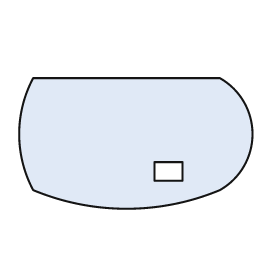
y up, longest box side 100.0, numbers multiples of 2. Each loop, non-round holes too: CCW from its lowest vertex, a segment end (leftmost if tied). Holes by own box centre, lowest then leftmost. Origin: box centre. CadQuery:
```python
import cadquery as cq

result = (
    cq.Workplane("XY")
    .moveTo(-44.0, -20.0)
    .threePointArc((-4.0, -28.0), (36.0, -20.0))
    .threePointArc((50.0, 4.0), (36.0, 28.0))
    .lineTo(-44.0, 28.0)
    .threePointArc((-50.0, 4.0), (-44.0, -20.0))
    .close()
    .moveTo(8.0, -16.0)
    .lineTo(20.0, -16.0)
    .lineTo(20.0, -8.0)
    .lineTo(8.0, -8.0)
    .close()
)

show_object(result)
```